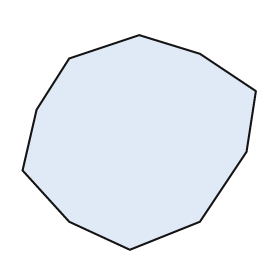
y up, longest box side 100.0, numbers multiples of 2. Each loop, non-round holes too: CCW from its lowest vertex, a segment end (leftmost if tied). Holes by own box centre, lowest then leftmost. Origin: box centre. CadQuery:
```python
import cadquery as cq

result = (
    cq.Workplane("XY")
    .moveTo(-4.0, -46.0)
    .lineTo(26.0, -34.0)
    .lineTo(46.0, -4.0)
    .lineTo(50.0, 22.0)
    .lineTo(26.0, 38.0)
    .lineTo(0.0, 46.0)
    .lineTo(-30.0, 36.0)
    .lineTo(-44.0, 14.0)
    .lineTo(-50.0, -12.0)
    .lineTo(-30.0, -34.0)
    .close()
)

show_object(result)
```